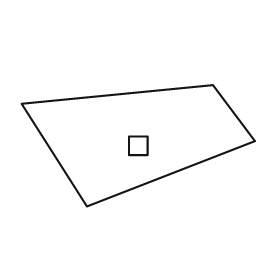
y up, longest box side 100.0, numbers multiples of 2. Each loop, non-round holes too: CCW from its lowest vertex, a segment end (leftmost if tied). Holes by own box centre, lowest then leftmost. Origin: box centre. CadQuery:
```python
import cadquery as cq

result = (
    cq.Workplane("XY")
    .moveTo(-22.0, -26.0)
    .lineTo(50.0, 2.0)
    .lineTo(32.0, 26.0)
    .lineTo(-50.0, 18.0)
    .close()
    .moveTo(-4.0, -4.0)
    .lineTo(4.0, -4.0)
    .lineTo(4.0, 4.0)
    .lineTo(-4.0, 4.0)
    .close()
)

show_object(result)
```